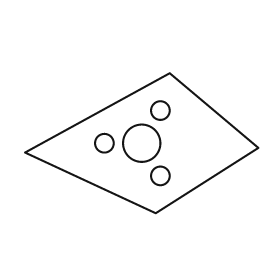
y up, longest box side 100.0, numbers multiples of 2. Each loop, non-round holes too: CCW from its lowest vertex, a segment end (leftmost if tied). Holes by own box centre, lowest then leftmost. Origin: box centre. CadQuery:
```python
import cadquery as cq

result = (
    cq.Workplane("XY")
    .moveTo(6.0, -30.0)
    .lineTo(50.0, -2.0)
    .lineTo(12.0, 30.0)
    .lineTo(-50.0, -4.0)
    .close()
    .moveTo(8.0, -14.0)
    .circle(4.0)
    .moveTo(-16.0, 0.0)
    .circle(4.0)
    .moveTo(0.0, 0.0)
    .circle(8.0)
    .moveTo(8.0, 14.0)
    .circle(4.0)
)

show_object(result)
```